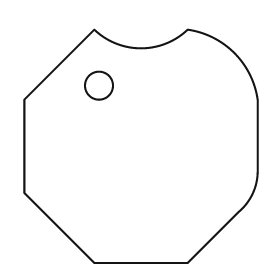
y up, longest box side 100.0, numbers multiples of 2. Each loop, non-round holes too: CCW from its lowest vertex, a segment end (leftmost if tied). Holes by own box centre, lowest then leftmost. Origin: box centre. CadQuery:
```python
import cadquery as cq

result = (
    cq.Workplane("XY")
    .moveTo(-20.0, -50.0)
    .lineTo(20.0, -50.0)
    .lineTo(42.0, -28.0)
    .threePointArc((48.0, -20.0), (50.0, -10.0))
    .lineTo(50.0, 20.0)
    .threePointArc((40.0, 40.0), (20.0, 50.0))
    .threePointArc((0.0, 42.0), (-20.0, 50.0))
    .lineTo(-50.0, 20.0)
    .lineTo(-50.0, -20.0)
    .close()
    .moveTo(-18.0, 26.0)
    .circle(6.0)
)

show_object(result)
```